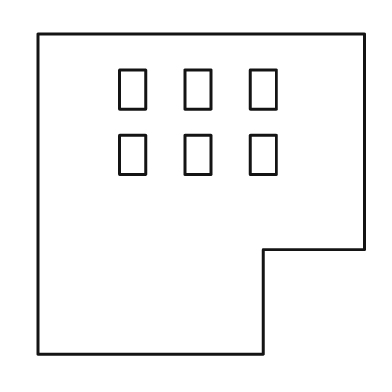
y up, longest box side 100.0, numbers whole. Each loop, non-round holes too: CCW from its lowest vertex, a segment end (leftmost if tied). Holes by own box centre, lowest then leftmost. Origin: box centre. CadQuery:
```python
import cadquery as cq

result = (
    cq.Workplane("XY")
    .moveTo(-50.0, -49.0)
    .lineTo(19.0, -49.0)
    .lineTo(19.0, -17.0)
    .lineTo(50.0, -17.0)
    .lineTo(50.0, 49.0)
    .lineTo(-50.0, 49.0)
    .close()
    .moveTo(-25.0, 6.0)
    .lineTo(-17.0, 6.0)
    .lineTo(-17.0, 18.0)
    .lineTo(-25.0, 18.0)
    .close()
    .moveTo(-5.0, 6.0)
    .lineTo(3.0, 6.0)
    .lineTo(3.0, 18.0)
    .lineTo(-5.0, 18.0)
    .close()
    .moveTo(15.0, 6.0)
    .lineTo(23.0, 6.0)
    .lineTo(23.0, 18.0)
    .lineTo(15.0, 18.0)
    .close()
    .moveTo(-25.0, 26.0)
    .lineTo(-17.0, 26.0)
    .lineTo(-17.0, 38.0)
    .lineTo(-25.0, 38.0)
    .close()
    .moveTo(-5.0, 26.0)
    .lineTo(3.0, 26.0)
    .lineTo(3.0, 38.0)
    .lineTo(-5.0, 38.0)
    .close()
    .moveTo(15.0, 26.0)
    .lineTo(23.0, 26.0)
    .lineTo(23.0, 38.0)
    .lineTo(15.0, 38.0)
    .close()
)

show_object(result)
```